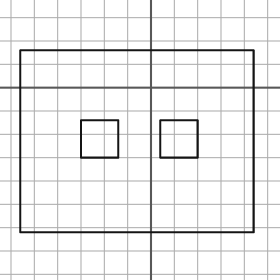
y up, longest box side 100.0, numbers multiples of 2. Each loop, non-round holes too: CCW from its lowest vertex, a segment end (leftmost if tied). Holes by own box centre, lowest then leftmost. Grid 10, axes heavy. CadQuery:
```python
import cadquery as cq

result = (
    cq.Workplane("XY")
    .moveTo(-56.0, -62.0)
    .lineTo(44.0, -62.0)
    .lineTo(44.0, 16.0)
    .lineTo(-56.0, 16.0)
    .close()
    .moveTo(-30.0, -30.0)
    .lineTo(-14.0, -30.0)
    .lineTo(-14.0, -14.0)
    .lineTo(-30.0, -14.0)
    .close()
    .moveTo(4.0, -30.0)
    .lineTo(20.0, -30.0)
    .lineTo(20.0, -14.0)
    .lineTo(4.0, -14.0)
    .close()
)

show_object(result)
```